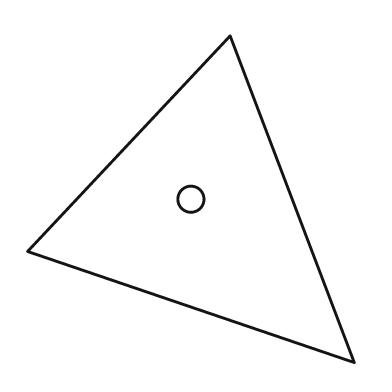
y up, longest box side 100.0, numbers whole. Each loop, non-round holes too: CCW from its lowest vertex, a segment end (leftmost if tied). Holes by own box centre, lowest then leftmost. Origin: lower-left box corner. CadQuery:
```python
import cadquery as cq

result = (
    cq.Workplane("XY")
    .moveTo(100.0, 0.0)
    .lineTo(62.0, 100.0)
    .lineTo(0.0, 34.0)
    .close()
    .moveTo(50.0, 50.0)
    .circle(4.0)
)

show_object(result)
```